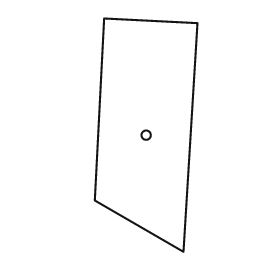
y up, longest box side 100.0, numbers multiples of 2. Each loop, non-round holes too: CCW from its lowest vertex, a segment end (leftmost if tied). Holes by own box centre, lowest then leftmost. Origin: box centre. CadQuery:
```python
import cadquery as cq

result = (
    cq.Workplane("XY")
    .moveTo(16.0, -50.0)
    .lineTo(22.0, 48.0)
    .lineTo(-18.0, 50.0)
    .lineTo(-22.0, -28.0)
    .close()
    .moveTo(0.0, 0.0)
    .circle(2.0)
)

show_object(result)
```